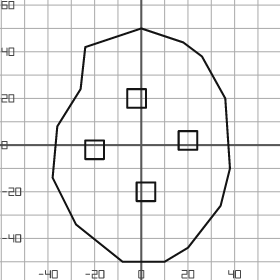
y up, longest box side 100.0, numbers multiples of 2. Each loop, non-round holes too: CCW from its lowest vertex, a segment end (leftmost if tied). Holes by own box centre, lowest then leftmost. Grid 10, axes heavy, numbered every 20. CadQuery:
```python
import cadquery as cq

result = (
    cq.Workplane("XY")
    .moveTo(-8.0, -50.0)
    .lineTo(10.0, -50.0)
    .lineTo(20.0, -44.0)
    .lineTo(34.0, -26.0)
    .lineTo(38.0, -10.0)
    .lineTo(36.0, 20.0)
    .lineTo(26.0, 38.0)
    .lineTo(18.0, 44.0)
    .lineTo(0.0, 50.0)
    .lineTo(-24.0, 42.0)
    .lineTo(-26.0, 24.0)
    .lineTo(-36.0, 8.0)
    .lineTo(-38.0, -14.0)
    .lineTo(-28.0, -34.0)
    .close()
    .moveTo(-2.0, -24.0)
    .lineTo(6.0, -24.0)
    .lineTo(6.0, -16.0)
    .lineTo(-2.0, -16.0)
    .close()
    .moveTo(-24.0, -6.0)
    .lineTo(-16.0, -6.0)
    .lineTo(-16.0, 2.0)
    .lineTo(-24.0, 2.0)
    .close()
    .moveTo(16.0, -2.0)
    .lineTo(24.0, -2.0)
    .lineTo(24.0, 6.0)
    .lineTo(16.0, 6.0)
    .close()
    .moveTo(-6.0, 16.0)
    .lineTo(2.0, 16.0)
    .lineTo(2.0, 24.0)
    .lineTo(-6.0, 24.0)
    .close()
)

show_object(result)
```